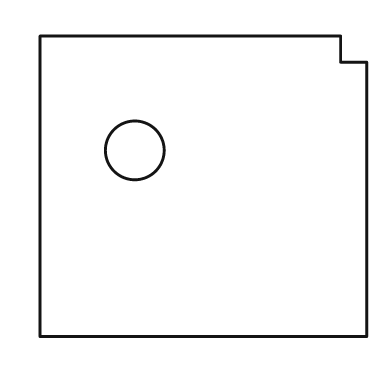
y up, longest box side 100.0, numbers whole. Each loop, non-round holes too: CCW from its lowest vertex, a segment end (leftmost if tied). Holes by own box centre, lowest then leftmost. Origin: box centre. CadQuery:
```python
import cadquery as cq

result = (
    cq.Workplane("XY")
    .moveTo(-50.0, -46.0)
    .lineTo(50.0, -46.0)
    .lineTo(50.0, 38.0)
    .lineTo(42.0, 38.0)
    .lineTo(42.0, 46.0)
    .lineTo(-50.0, 46.0)
    .close()
    .moveTo(-21.0, 11.0)
    .circle(9.0)
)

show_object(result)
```